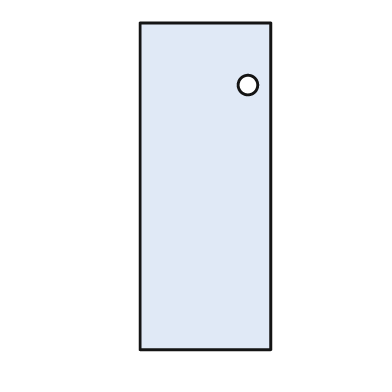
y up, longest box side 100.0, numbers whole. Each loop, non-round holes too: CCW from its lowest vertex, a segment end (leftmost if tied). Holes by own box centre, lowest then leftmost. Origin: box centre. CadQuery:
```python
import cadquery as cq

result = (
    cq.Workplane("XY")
    .moveTo(-20.0, -50.0)
    .lineTo(20.0, -50.0)
    .lineTo(20.0, 50.0)
    .lineTo(-20.0, 50.0)
    .close()
    .moveTo(13.0, 31.0)
    .circle(3.0)
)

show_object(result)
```